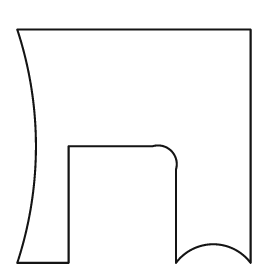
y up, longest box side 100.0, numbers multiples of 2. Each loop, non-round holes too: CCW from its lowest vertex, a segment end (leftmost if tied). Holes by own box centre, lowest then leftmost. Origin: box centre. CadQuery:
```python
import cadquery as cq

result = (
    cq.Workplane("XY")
    .moveTo(-50.0, -50.0)
    .lineTo(-28.0, -50.0)
    .lineTo(-28.0, 0.0)
    .lineTo(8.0, 0.0)
    .threePointArc((16.0, -2.0), (18.0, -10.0))
    .lineTo(18.0, -50.0)
    .threePointArc((34.0, -42.0), (50.0, -50.0))
    .lineTo(50.0, 50.0)
    .lineTo(-50.0, 50.0)
    .threePointArc((-42.0, 0.0), (-50.0, -50.0))
    .close()
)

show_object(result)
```